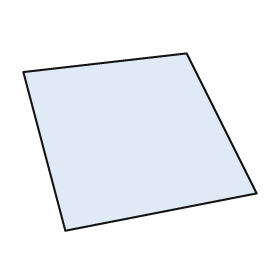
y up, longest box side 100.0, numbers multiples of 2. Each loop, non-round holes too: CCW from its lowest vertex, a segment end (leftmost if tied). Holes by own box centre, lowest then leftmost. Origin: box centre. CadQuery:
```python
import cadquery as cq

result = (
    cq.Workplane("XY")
    .moveTo(-32.0, -38.0)
    .lineTo(50.0, -22.0)
    .lineTo(20.0, 38.0)
    .lineTo(-50.0, 30.0)
    .close()
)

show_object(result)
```